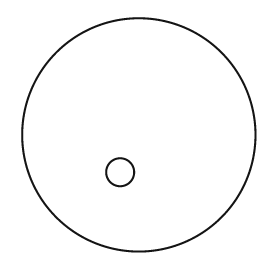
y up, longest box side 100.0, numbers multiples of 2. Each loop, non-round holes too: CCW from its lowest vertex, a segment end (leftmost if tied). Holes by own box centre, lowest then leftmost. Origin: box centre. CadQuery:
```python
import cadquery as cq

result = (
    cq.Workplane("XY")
    .moveTo(0.0, 0.0)
    .circle(50.0)
    .moveTo(-8.0, -16.0)
    .circle(6.0)
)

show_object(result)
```